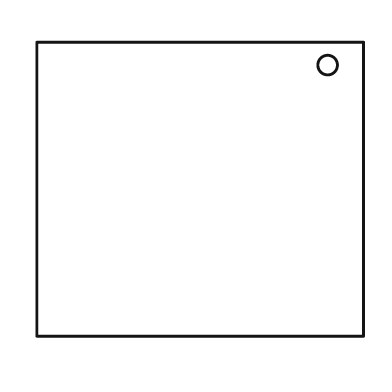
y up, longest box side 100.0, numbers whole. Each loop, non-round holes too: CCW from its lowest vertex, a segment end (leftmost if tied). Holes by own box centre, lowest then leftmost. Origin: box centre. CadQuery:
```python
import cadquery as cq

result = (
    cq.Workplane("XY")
    .moveTo(-50.0, -45.0)
    .lineTo(50.0, -45.0)
    .lineTo(50.0, 45.0)
    .lineTo(-50.0, 45.0)
    .close()
    .moveTo(39.0, 38.0)
    .circle(3.0)
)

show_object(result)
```